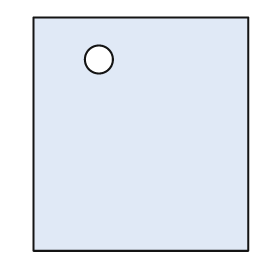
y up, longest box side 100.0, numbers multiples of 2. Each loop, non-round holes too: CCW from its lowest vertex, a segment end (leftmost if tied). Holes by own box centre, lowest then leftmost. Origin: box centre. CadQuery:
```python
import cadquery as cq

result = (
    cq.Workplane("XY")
    .moveTo(-46.0, -50.0)
    .lineTo(46.0, -50.0)
    .lineTo(46.0, 50.0)
    .lineTo(-46.0, 50.0)
    .close()
    .moveTo(-18.0, 32.0)
    .circle(6.0)
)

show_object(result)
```